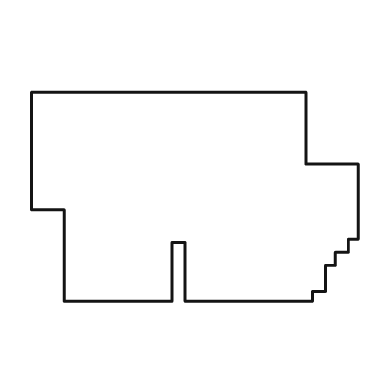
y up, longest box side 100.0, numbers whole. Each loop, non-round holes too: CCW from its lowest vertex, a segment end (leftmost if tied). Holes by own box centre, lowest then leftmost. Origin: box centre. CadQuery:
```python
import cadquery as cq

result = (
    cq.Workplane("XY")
    .moveTo(-40.0, -32.0)
    .lineTo(-7.0, -32.0)
    .lineTo(-7.0, -14.0)
    .lineTo(-3.0, -14.0)
    .lineTo(-3.0, -32.0)
    .lineTo(36.0, -32.0)
    .lineTo(36.0, -29.0)
    .lineTo(40.0, -29.0)
    .lineTo(40.0, -21.0)
    .lineTo(43.0, -21.0)
    .lineTo(43.0, -17.0)
    .lineTo(47.0, -17.0)
    .lineTo(47.0, -13.0)
    .lineTo(50.0, -13.0)
    .lineTo(50.0, 10.0)
    .lineTo(34.0, 10.0)
    .lineTo(34.0, 32.0)
    .lineTo(-50.0, 32.0)
    .lineTo(-50.0, -4.0)
    .lineTo(-40.0, -4.0)
    .close()
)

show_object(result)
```